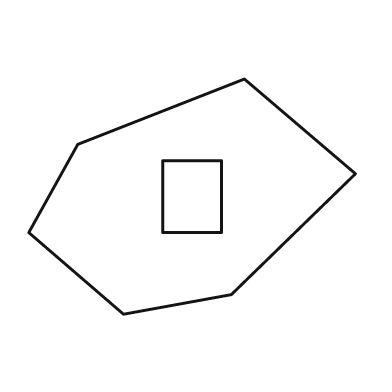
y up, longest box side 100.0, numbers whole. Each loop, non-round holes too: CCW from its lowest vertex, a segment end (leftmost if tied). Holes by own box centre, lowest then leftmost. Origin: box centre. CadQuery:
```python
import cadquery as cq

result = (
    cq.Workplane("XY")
    .moveTo(-21.0, -36.0)
    .lineTo(12.0, -30.0)
    .lineTo(50.0, 7.0)
    .lineTo(16.0, 36.0)
    .lineTo(-35.0, 16.0)
    .lineTo(-50.0, -11.0)
    .close()
    .moveTo(-9.0, -11.0)
    .lineTo(9.0, -11.0)
    .lineTo(9.0, 11.0)
    .lineTo(-9.0, 11.0)
    .close()
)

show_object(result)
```